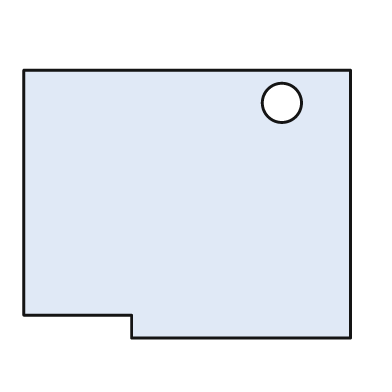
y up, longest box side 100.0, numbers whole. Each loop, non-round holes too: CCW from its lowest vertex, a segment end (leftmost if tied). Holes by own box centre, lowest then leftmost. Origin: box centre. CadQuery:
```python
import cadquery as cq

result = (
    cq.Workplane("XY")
    .moveTo(-17.0, -41.0)
    .lineTo(50.0, -41.0)
    .lineTo(50.0, 41.0)
    .lineTo(-50.0, 41.0)
    .lineTo(-50.0, -34.0)
    .lineTo(-17.0, -34.0)
    .close()
    .moveTo(29.0, 31.0)
    .circle(6.0)
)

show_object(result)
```